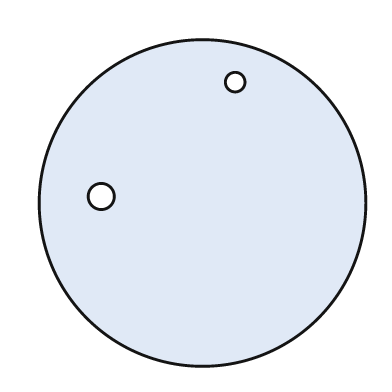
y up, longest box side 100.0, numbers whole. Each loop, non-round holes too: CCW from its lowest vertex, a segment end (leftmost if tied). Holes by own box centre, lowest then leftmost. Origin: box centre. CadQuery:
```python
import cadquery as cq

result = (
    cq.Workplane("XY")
    .moveTo(0.0, 0.0)
    .circle(50.0)
    .moveTo(-31.0, 2.0)
    .circle(4.0)
    .moveTo(10.0, 37.0)
    .circle(3.0)
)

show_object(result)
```